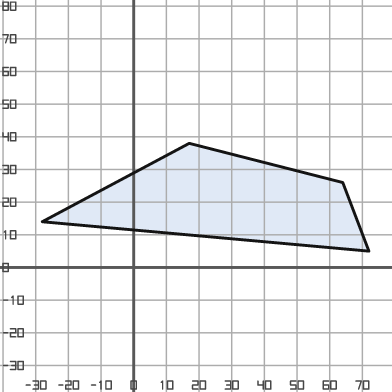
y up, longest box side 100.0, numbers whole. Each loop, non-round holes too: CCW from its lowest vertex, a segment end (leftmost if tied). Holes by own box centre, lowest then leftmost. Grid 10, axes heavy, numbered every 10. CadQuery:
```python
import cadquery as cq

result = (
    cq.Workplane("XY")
    .moveTo(72.0, 5.0)
    .lineTo(64.0, 26.0)
    .lineTo(17.0, 38.0)
    .lineTo(-28.0, 14.0)
    .close()
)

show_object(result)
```